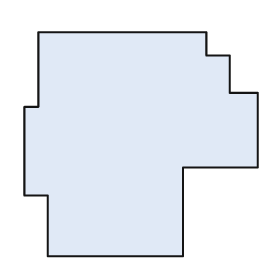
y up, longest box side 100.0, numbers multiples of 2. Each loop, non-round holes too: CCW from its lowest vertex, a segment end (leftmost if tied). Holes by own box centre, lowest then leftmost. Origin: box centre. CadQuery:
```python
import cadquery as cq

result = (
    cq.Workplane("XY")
    .moveTo(-40.0, -48.0)
    .lineTo(18.0, -48.0)
    .lineTo(18.0, -10.0)
    .lineTo(50.0, -10.0)
    .lineTo(50.0, 22.0)
    .lineTo(38.0, 22.0)
    .lineTo(38.0, 38.0)
    .lineTo(28.0, 38.0)
    .lineTo(28.0, 48.0)
    .lineTo(-44.0, 48.0)
    .lineTo(-44.0, 16.0)
    .lineTo(-50.0, 16.0)
    .lineTo(-50.0, -22.0)
    .lineTo(-40.0, -22.0)
    .close()
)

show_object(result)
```